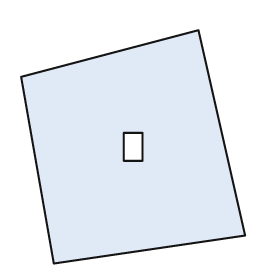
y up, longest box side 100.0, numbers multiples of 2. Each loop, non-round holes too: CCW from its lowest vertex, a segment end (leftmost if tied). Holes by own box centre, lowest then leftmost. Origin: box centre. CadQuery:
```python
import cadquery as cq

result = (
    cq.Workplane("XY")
    .moveTo(-34.0, -50.0)
    .lineTo(48.0, -38.0)
    .lineTo(28.0, 50.0)
    .lineTo(-48.0, 30.0)
    .close()
    .moveTo(-4.0, -6.0)
    .lineTo(4.0, -6.0)
    .lineTo(4.0, 6.0)
    .lineTo(-4.0, 6.0)
    .close()
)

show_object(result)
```